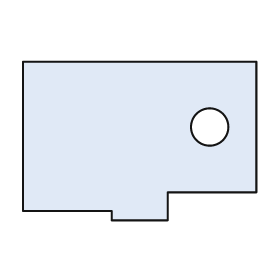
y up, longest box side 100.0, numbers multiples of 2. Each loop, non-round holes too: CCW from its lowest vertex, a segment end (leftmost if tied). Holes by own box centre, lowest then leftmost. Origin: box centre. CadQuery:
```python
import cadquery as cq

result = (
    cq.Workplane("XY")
    .moveTo(-12.0, -34.0)
    .lineTo(12.0, -34.0)
    .lineTo(12.0, -22.0)
    .lineTo(50.0, -22.0)
    .lineTo(50.0, 34.0)
    .lineTo(-50.0, 34.0)
    .lineTo(-50.0, -30.0)
    .lineTo(-12.0, -30.0)
    .close()
    .moveTo(30.0, 6.0)
    .circle(8.0)
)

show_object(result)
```